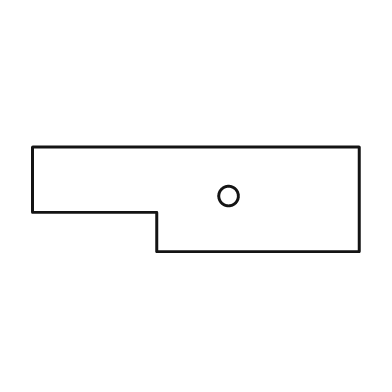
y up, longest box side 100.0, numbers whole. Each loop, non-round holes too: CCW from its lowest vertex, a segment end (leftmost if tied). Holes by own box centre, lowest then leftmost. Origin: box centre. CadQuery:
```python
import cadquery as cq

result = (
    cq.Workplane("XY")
    .moveTo(-12.0, -16.0)
    .lineTo(50.0, -16.0)
    .lineTo(50.0, 16.0)
    .lineTo(-50.0, 16.0)
    .lineTo(-50.0, -4.0)
    .lineTo(-12.0, -4.0)
    .close()
    .moveTo(10.0, 1.0)
    .circle(3.0)
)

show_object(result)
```